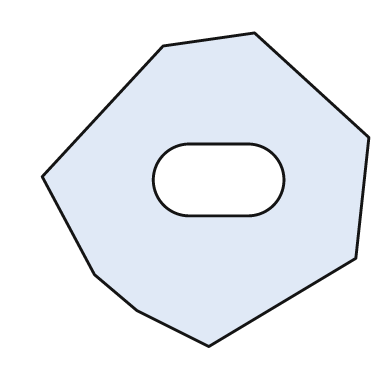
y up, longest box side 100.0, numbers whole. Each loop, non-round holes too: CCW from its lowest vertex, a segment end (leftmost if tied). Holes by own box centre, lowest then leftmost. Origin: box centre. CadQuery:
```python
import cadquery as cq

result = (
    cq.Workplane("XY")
    .moveTo(1.0, -48.0)
    .lineTo(46.0, -21.0)
    .lineTo(50.0, 16.0)
    .lineTo(15.0, 48.0)
    .lineTo(-13.0, 44.0)
    .lineTo(-50.0, 4.0)
    .lineTo(-34.0, -26.0)
    .lineTo(-21.0, -37.0)
    .close()
    .moveTo(-5.0, -8.0)
    .lineTo(13.0, -8.0)
    .threePointArc((24.0, 3.0), (13.0, 14.0))
    .lineTo(-5.0, 14.0)
    .threePointArc((-16.0, 3.0), (-5.0, -8.0))
    .close()
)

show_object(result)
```